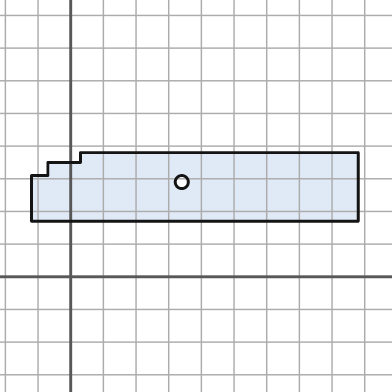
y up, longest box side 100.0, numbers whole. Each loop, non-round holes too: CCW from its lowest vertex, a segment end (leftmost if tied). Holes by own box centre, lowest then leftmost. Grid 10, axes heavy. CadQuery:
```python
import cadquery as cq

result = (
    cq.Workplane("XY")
    .moveTo(-12.0, 17.0)
    .lineTo(88.0, 17.0)
    .lineTo(88.0, 38.0)
    .lineTo(3.0, 38.0)
    .lineTo(3.0, 35.0)
    .lineTo(-7.0, 35.0)
    .lineTo(-7.0, 31.0)
    .lineTo(-12.0, 31.0)
    .close()
    .moveTo(34.0, 29.0)
    .circle(2.0)
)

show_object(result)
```